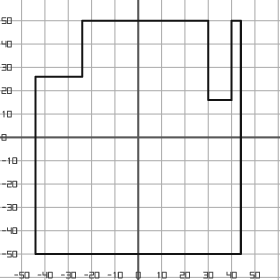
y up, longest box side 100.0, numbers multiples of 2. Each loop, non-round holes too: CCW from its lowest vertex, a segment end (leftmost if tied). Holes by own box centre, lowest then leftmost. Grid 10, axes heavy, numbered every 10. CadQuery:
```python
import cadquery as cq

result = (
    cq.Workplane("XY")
    .moveTo(-44.0, -50.0)
    .lineTo(44.0, -50.0)
    .lineTo(44.0, 50.0)
    .lineTo(40.0, 50.0)
    .lineTo(40.0, 16.0)
    .lineTo(30.0, 16.0)
    .lineTo(30.0, 50.0)
    .lineTo(-24.0, 50.0)
    .lineTo(-24.0, 26.0)
    .lineTo(-44.0, 26.0)
    .close()
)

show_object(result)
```